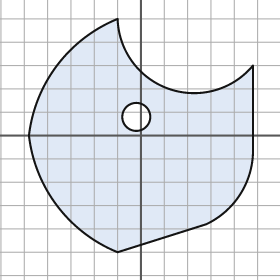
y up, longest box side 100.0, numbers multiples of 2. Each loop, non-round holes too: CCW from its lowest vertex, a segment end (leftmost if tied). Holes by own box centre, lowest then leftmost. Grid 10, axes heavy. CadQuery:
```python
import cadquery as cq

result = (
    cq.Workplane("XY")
    .moveTo(-10.0, -50.0)
    .lineTo(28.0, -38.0)
    .threePointArc((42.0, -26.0), (48.0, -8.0))
    .lineTo(48.0, 30.0)
    .threePointArc((12.0, 20.0), (-10.0, 50.0))
    .threePointArc((-36.0, 30.0), (-48.0, 0.0))
    .threePointArc((-36.0, -30.0), (-10.0, -50.0))
    .close()
    .moveTo(-2.0, 8.0)
    .circle(6.0)
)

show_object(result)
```